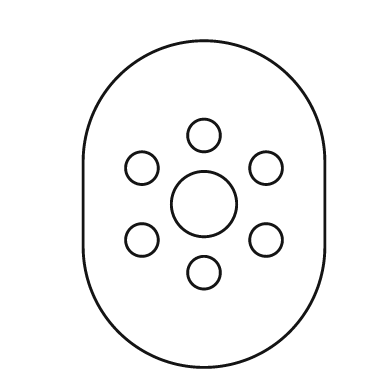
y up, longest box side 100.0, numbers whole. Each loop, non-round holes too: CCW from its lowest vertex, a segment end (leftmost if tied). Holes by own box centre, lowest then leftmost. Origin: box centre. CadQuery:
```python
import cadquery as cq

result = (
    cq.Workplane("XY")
    .moveTo(-37.0, -13.0)
    .threePointArc((0.0, -50.0), (37.0, -13.0))
    .lineTo(37.0, 13.0)
    .threePointArc((0.0, 50.0), (-37.0, 13.0))
    .close()
    .moveTo(0.0, -21.0)
    .circle(5.0)
    .moveTo(-19.0, -11.0)
    .circle(5.0)
    .moveTo(19.0, -11.0)
    .circle(5.0)
    .moveTo(0.0, 0.0)
    .circle(10.0)
    .moveTo(-19.0, 11.0)
    .circle(5.0)
    .moveTo(19.0, 11.0)
    .circle(5.0)
    .moveTo(0.0, 21.0)
    .circle(5.0)
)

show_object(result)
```